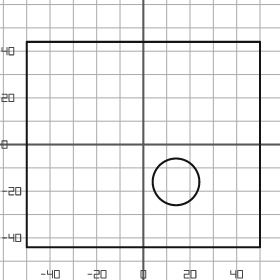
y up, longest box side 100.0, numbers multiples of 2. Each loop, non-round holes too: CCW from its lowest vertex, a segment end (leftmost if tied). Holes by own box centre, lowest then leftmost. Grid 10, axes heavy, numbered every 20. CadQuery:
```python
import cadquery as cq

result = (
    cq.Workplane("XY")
    .moveTo(-50.0, -44.0)
    .lineTo(50.0, -44.0)
    .lineTo(50.0, 44.0)
    .lineTo(-50.0, 44.0)
    .close()
    .moveTo(14.0, -16.0)
    .circle(10.0)
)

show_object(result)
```